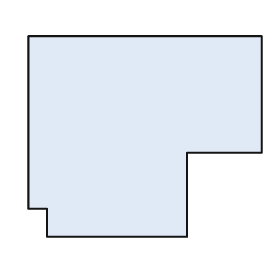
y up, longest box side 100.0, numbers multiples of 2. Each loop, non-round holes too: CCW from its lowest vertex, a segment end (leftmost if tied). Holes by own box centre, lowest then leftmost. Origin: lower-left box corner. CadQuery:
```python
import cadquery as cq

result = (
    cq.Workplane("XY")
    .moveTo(8.0, 0.0)
    .lineTo(68.0, 0.0)
    .lineTo(68.0, 36.0)
    .lineTo(100.0, 36.0)
    .lineTo(100.0, 86.0)
    .lineTo(0.0, 86.0)
    .lineTo(0.0, 12.0)
    .lineTo(8.0, 12.0)
    .close()
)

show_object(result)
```